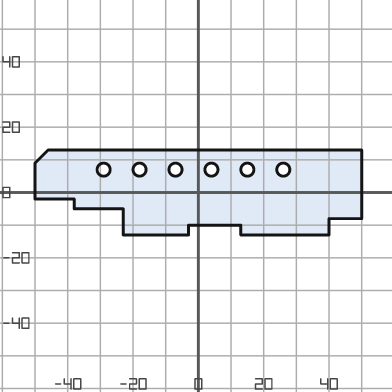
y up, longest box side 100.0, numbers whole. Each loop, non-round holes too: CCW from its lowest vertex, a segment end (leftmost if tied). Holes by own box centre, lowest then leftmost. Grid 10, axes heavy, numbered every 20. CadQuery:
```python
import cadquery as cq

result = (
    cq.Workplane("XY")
    .moveTo(-23.0, -13.0)
    .lineTo(-3.0, -13.0)
    .lineTo(-3.0, -10.0)
    .lineTo(13.0, -10.0)
    .lineTo(13.0, -13.0)
    .lineTo(40.0, -13.0)
    .lineTo(40.0, -8.0)
    .lineTo(50.0, -8.0)
    .lineTo(50.0, 13.0)
    .lineTo(-46.0, 13.0)
    .lineTo(-50.0, 9.0)
    .lineTo(-50.0, -2.0)
    .lineTo(-38.0, -2.0)
    .lineTo(-38.0, -5.0)
    .lineTo(-23.0, -5.0)
    .close()
    .moveTo(-29.0, 7.0)
    .circle(2.0)
    .moveTo(-18.0, 7.0)
    .circle(2.0)
    .moveTo(-7.0, 7.0)
    .circle(2.0)
    .moveTo(4.0, 7.0)
    .circle(2.0)
    .moveTo(15.0, 7.0)
    .circle(2.0)
    .moveTo(26.0, 7.0)
    .circle(2.0)
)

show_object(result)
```